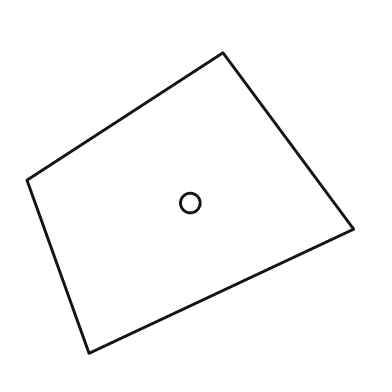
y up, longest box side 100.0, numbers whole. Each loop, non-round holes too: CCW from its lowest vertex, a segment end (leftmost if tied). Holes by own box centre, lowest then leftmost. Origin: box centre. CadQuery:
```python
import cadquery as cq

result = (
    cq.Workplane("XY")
    .moveTo(-31.0, -46.0)
    .lineTo(50.0, -8.0)
    .lineTo(10.0, 46.0)
    .lineTo(-50.0, 7.0)
    .close()
    .moveTo(0.0, 0.0)
    .circle(3.0)
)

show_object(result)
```